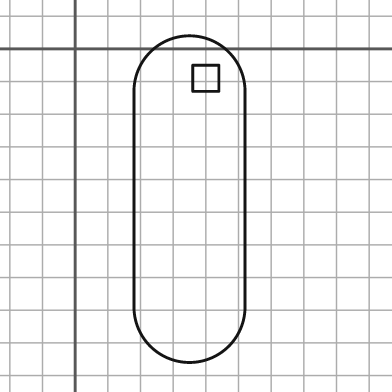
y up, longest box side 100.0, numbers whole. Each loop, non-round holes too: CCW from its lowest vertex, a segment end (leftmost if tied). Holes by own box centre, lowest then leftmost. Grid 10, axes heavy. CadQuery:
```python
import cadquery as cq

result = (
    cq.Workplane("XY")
    .moveTo(18.0, -79.0)
    .threePointArc((35.0, -96.0), (52.0, -79.0))
    .lineTo(52.0, -13.0)
    .threePointArc((35.0, 4.0), (18.0, -13.0))
    .close()
    .moveTo(36.0, -13.0)
    .lineTo(44.0, -13.0)
    .lineTo(44.0, -5.0)
    .lineTo(36.0, -5.0)
    .close()
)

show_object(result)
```